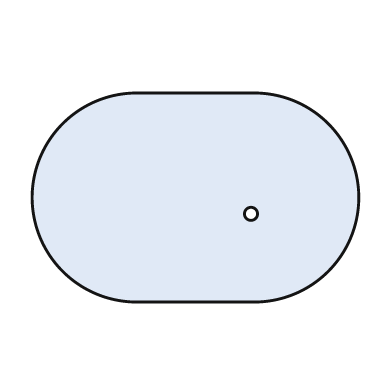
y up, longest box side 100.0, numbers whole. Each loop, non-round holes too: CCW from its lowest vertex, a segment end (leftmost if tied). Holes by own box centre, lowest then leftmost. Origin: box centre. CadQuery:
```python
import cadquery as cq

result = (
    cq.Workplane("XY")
    .moveTo(-18.0, -32.0)
    .lineTo(18.0, -32.0)
    .threePointArc((50.0, 0.0), (18.0, 32.0))
    .lineTo(-18.0, 32.0)
    .threePointArc((-50.0, 0.0), (-18.0, -32.0))
    .close()
    .moveTo(17.0, -5.0)
    .circle(2.0)
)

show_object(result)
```